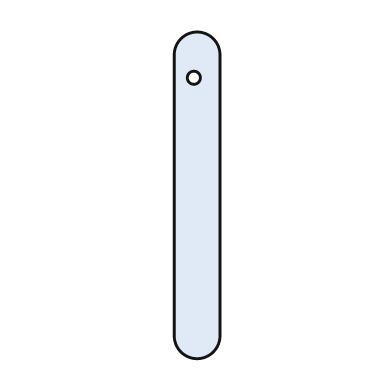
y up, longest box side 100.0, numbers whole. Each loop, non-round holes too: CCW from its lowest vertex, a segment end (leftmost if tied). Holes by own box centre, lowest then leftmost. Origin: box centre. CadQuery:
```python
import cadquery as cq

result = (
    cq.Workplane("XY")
    .moveTo(-7.0, -43.0)
    .threePointArc((0.0, -50.0), (7.0, -43.0))
    .lineTo(7.0, 43.0)
    .threePointArc((0.0, 50.0), (-7.0, 43.0))
    .close()
    .moveTo(-1.0, 36.0)
    .circle(2.0)
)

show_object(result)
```